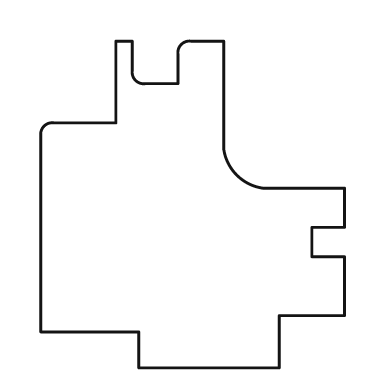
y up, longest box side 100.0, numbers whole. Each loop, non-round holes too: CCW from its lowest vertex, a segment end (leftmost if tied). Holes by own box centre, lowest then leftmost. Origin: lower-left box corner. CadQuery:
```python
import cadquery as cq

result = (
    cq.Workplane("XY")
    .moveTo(30.0, 0.0)
    .lineTo(73.0, 0.0)
    .lineTo(73.0, 16.0)
    .lineTo(93.0, 16.0)
    .lineTo(93.0, 34.0)
    .lineTo(83.0, 34.0)
    .lineTo(83.0, 43.0)
    .lineTo(93.0, 43.0)
    .lineTo(93.0, 55.0)
    .lineTo(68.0, 55.0)
    .threePointArc((60.0, 59.0), (56.0, 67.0))
    .lineTo(56.0, 100.0)
    .lineTo(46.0, 100.0)
    .threePointArc((43.0, 99.0), (42.0, 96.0))
    .lineTo(42.0, 87.0)
    .lineTo(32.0, 87.0)
    .threePointArc((29.0, 88.0), (28.0, 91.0))
    .lineTo(28.0, 100.0)
    .lineTo(23.0, 100.0)
    .lineTo(23.0, 75.0)
    .lineTo(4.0, 75.0)
    .threePointArc((1.0, 74.0), (0.0, 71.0))
    .lineTo(0.0, 11.0)
    .lineTo(30.0, 11.0)
    .close()
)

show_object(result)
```